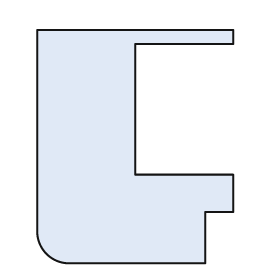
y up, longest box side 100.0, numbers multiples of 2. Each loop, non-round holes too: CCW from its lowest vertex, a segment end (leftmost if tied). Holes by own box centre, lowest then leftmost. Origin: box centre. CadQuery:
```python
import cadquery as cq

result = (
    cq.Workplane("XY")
    .moveTo(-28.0, -50.0)
    .lineTo(30.0, -50.0)
    .lineTo(30.0, -28.0)
    .lineTo(42.0, -28.0)
    .lineTo(42.0, -12.0)
    .lineTo(0.0, -12.0)
    .lineTo(0.0, 44.0)
    .lineTo(42.0, 44.0)
    .lineTo(42.0, 50.0)
    .lineTo(-42.0, 50.0)
    .lineTo(-42.0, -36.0)
    .threePointArc((-38.0, -46.0), (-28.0, -50.0))
    .close()
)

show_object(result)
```